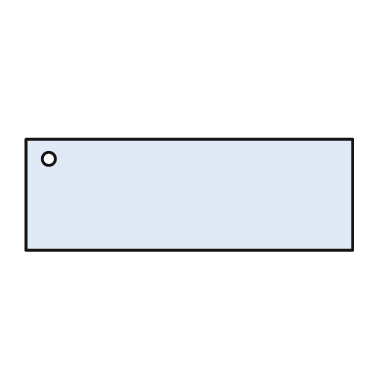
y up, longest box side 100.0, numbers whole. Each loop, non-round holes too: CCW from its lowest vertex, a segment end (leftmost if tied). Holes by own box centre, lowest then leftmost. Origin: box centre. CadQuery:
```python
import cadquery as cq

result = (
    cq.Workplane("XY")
    .moveTo(-50.0, -17.0)
    .lineTo(50.0, -17.0)
    .lineTo(50.0, 17.0)
    .lineTo(-50.0, 17.0)
    .close()
    .moveTo(-43.0, 11.0)
    .circle(2.0)
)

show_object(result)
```